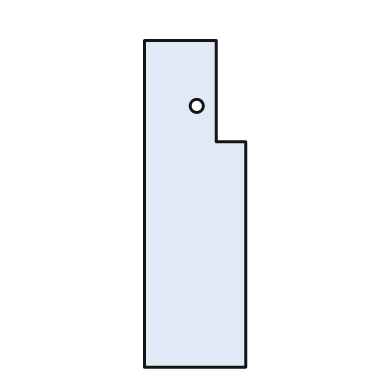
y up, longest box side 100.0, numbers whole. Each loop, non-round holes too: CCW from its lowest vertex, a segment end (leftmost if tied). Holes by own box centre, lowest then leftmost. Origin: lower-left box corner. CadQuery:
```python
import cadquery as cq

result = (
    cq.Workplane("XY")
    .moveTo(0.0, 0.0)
    .lineTo(31.0, 0.0)
    .lineTo(31.0, 69.0)
    .lineTo(22.0, 69.0)
    .lineTo(22.0, 100.0)
    .lineTo(0.0, 100.0)
    .close()
    .moveTo(16.0, 80.0)
    .circle(2.0)
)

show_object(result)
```